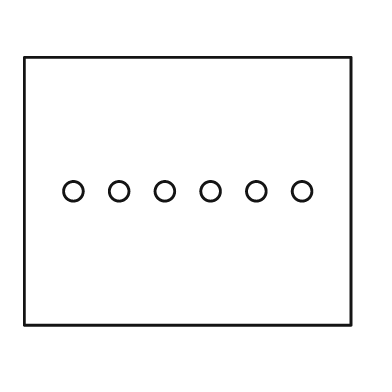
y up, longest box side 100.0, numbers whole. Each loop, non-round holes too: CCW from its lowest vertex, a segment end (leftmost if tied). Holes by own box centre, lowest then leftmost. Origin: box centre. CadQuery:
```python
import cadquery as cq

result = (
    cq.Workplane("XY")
    .moveTo(-50.0, -41.0)
    .lineTo(50.0, -41.0)
    .lineTo(50.0, 41.0)
    .lineTo(-50.0, 41.0)
    .close()
    .moveTo(-35.0, 0.0)
    .circle(3.0)
    .moveTo(-21.0, 0.0)
    .circle(3.0)
    .moveTo(-7.0, 0.0)
    .circle(3.0)
    .moveTo(7.0, 0.0)
    .circle(3.0)
    .moveTo(21.0, 0.0)
    .circle(3.0)
    .moveTo(35.0, 0.0)
    .circle(3.0)
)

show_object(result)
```